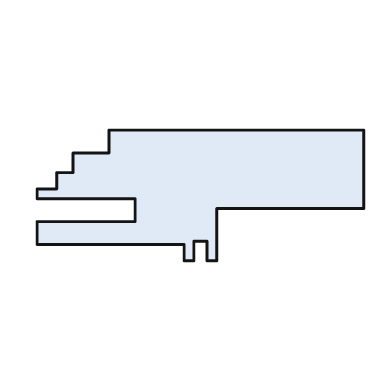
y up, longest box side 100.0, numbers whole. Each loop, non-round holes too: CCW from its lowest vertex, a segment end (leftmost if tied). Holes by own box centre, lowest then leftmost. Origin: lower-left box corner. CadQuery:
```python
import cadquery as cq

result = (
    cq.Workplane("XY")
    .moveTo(45.0, 0.0)
    .lineTo(48.0, 0.0)
    .lineTo(48.0, 6.0)
    .lineTo(52.0, 6.0)
    .lineTo(52.0, 0.0)
    .lineTo(55.0, 0.0)
    .lineTo(55.0, 16.0)
    .lineTo(100.0, 16.0)
    .lineTo(100.0, 40.0)
    .lineTo(22.0, 40.0)
    .lineTo(22.0, 33.0)
    .lineTo(11.0, 33.0)
    .lineTo(11.0, 27.0)
    .lineTo(6.0, 27.0)
    .lineTo(6.0, 22.0)
    .lineTo(0.0, 22.0)
    .lineTo(0.0, 19.0)
    .lineTo(30.0, 19.0)
    .lineTo(30.0, 12.0)
    .lineTo(0.0, 12.0)
    .lineTo(0.0, 5.0)
    .lineTo(45.0, 5.0)
    .close()
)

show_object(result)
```